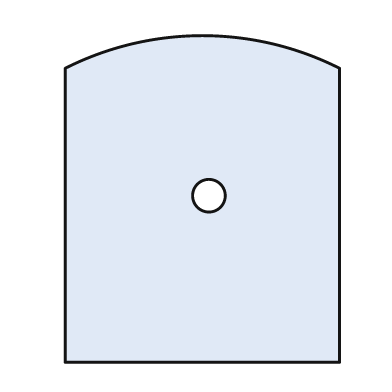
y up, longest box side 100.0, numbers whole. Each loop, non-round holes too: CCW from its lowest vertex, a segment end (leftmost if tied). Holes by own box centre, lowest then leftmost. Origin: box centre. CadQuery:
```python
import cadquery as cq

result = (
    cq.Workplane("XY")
    .moveTo(-42.0, -50.0)
    .lineTo(42.0, -50.0)
    .lineTo(42.0, 40.0)
    .threePointArc((0.0, 50.0), (-42.0, 40.0))
    .close()
    .moveTo(2.0, 1.0)
    .circle(5.0)
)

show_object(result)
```